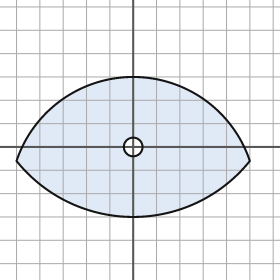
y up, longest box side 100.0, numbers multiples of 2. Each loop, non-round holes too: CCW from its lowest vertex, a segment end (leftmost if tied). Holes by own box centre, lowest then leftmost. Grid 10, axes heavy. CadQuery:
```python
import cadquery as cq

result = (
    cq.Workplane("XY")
    .moveTo(-50.0, -6.0)
    .threePointArc((0.0, -30.0), (50.0, -6.0))
    .threePointArc((0.0, 30.0), (-50.0, -6.0))
    .close()
    .moveTo(0.0, 0.0)
    .circle(4.0)
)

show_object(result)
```